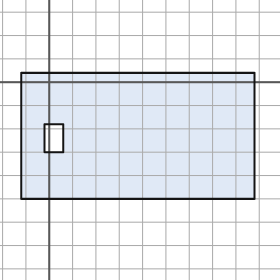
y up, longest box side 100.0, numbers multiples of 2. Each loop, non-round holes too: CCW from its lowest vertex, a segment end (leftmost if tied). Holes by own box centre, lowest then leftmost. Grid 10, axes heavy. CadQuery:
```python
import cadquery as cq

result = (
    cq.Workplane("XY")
    .moveTo(-12.0, -50.0)
    .lineTo(88.0, -50.0)
    .lineTo(88.0, 4.0)
    .lineTo(-12.0, 4.0)
    .close()
    .moveTo(-2.0, -30.0)
    .lineTo(6.0, -30.0)
    .lineTo(6.0, -18.0)
    .lineTo(-2.0, -18.0)
    .close()
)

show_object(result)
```